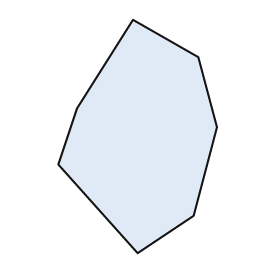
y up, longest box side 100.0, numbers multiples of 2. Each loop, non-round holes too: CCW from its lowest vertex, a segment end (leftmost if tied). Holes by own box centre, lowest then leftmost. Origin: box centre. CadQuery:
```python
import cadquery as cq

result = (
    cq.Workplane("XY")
    .moveTo(0.0, -50.0)
    .lineTo(24.0, -34.0)
    .lineTo(34.0, 4.0)
    .lineTo(26.0, 34.0)
    .lineTo(-2.0, 50.0)
    .lineTo(-26.0, 12.0)
    .lineTo(-34.0, -12.0)
    .close()
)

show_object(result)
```